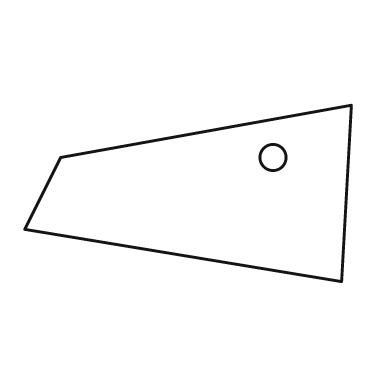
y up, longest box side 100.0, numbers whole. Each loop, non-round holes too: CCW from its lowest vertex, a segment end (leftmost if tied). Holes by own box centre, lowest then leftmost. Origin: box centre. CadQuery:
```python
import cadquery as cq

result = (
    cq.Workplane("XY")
    .moveTo(47.0, -27.0)
    .lineTo(50.0, 27.0)
    .lineTo(-39.0, 11.0)
    .lineTo(-50.0, -11.0)
    .close()
    .moveTo(26.0, 11.0)
    .circle(4.0)
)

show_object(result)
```